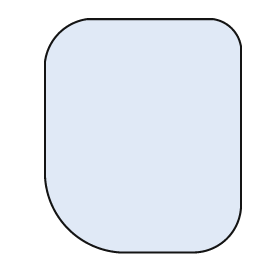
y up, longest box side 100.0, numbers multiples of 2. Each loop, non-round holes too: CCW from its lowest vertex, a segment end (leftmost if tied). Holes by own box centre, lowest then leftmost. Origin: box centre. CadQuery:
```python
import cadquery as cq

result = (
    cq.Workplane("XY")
    .moveTo(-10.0, -50.0)
    .lineTo(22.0, -50.0)
    .threePointArc((36.0, -44.0), (42.0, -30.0))
    .lineTo(42.0, 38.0)
    .threePointArc((38.0, 46.0), (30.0, 50.0))
    .lineTo(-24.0, 50.0)
    .threePointArc((-36.0, 44.0), (-42.0, 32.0))
    .lineTo(-42.0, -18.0)
    .threePointArc((-32.0, -40.0), (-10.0, -50.0))
    .close()
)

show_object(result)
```